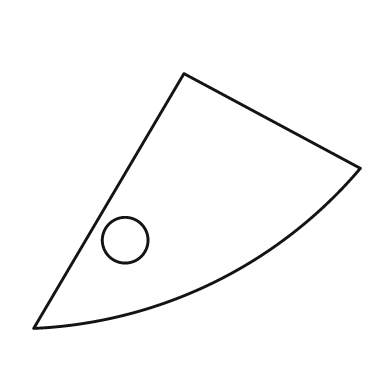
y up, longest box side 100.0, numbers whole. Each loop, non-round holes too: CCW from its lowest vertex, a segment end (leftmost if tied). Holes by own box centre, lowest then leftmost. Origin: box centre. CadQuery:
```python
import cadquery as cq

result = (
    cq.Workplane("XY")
    .moveTo(-50.0, -39.0)
    .threePointArc((5.0, -25.0), (50.0, 10.0))
    .lineTo(-4.0, 39.0)
    .close()
    .moveTo(-22.0, -12.0)
    .circle(7.0)
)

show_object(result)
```